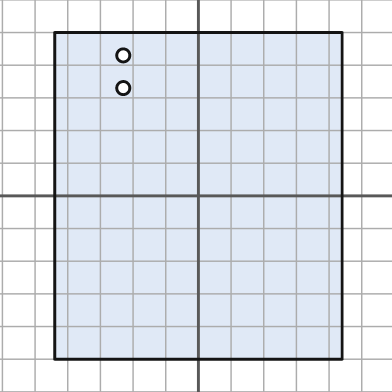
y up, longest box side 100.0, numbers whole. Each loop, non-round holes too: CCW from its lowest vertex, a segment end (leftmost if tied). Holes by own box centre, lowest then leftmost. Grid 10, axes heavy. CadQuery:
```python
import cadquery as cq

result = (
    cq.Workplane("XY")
    .moveTo(-44.0, -50.0)
    .lineTo(44.0, -50.0)
    .lineTo(44.0, 50.0)
    .lineTo(-44.0, 50.0)
    .close()
    .moveTo(-23.0, 33.0)
    .circle(2.0)
    .moveTo(-23.0, 43.0)
    .circle(2.0)
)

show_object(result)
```